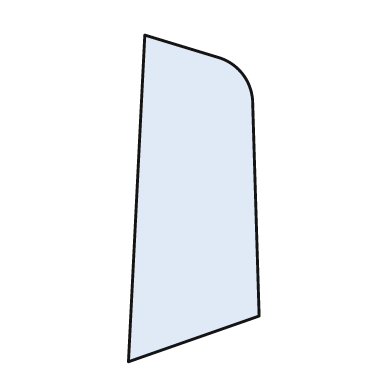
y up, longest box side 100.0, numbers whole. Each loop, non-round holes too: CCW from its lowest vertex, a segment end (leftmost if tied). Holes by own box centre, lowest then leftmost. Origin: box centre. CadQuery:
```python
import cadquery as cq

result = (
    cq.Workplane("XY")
    .moveTo(-20.0, -50.0)
    .lineTo(20.0, -36.0)
    .lineTo(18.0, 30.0)
    .threePointArc((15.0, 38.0), (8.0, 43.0))
    .lineTo(-15.0, 50.0)
    .close()
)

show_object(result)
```